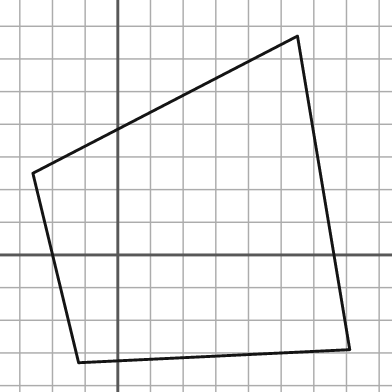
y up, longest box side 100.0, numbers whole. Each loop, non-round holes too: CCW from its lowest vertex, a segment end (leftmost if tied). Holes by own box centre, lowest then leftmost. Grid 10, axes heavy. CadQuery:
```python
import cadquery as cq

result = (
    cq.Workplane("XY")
    .moveTo(-12.0, -33.0)
    .lineTo(71.0, -29.0)
    .lineTo(55.0, 67.0)
    .lineTo(-26.0, 25.0)
    .close()
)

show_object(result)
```